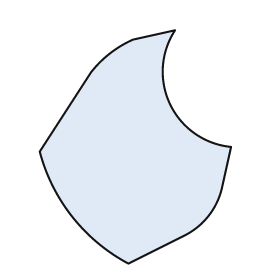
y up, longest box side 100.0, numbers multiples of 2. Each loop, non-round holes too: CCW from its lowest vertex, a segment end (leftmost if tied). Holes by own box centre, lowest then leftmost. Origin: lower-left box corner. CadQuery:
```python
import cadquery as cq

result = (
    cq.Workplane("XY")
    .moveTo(38.0, 0.0)
    .lineTo(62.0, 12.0)
    .threePointArc((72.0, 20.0), (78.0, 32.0))
    .lineTo(82.0, 50.0)
    .threePointArc((56.0, 68.0), (58.0, 100.0))
    .lineTo(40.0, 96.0)
    .threePointArc((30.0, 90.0), (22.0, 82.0))
    .lineTo(0.0, 48.0)
    .threePointArc((14.0, 20.0), (38.0, 0.0))
    .close()
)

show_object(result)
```